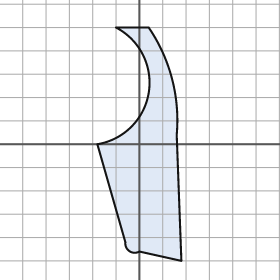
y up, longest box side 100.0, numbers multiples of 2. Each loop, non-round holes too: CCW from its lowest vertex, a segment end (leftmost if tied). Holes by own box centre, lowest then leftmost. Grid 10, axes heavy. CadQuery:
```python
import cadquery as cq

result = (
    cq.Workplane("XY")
    .moveTo(18.0, -50.0)
    .lineTo(16.0, 4.0)
    .threePointArc((14.0, 28.0), (4.0, 50.0))
    .lineTo(-10.0, 50.0)
    .threePointArc((4.0, 22.0), (-18.0, 0.0))
    .lineTo(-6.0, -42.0)
    .threePointArc((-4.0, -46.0), (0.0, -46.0))
    .close()
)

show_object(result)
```